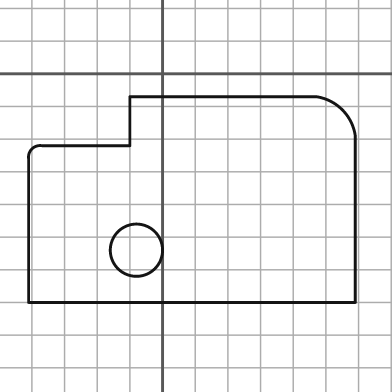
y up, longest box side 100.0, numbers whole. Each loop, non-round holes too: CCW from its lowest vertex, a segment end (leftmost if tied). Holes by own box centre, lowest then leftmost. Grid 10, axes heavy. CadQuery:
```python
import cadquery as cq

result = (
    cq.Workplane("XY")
    .moveTo(-41.0, -70.0)
    .lineTo(59.0, -70.0)
    .lineTo(59.0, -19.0)
    .threePointArc((55.0, -11.0), (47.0, -7.0))
    .lineTo(-10.0, -7.0)
    .lineTo(-10.0, -22.0)
    .lineTo(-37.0, -22.0)
    .threePointArc((-40.0, -23.0), (-41.0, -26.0))
    .close()
    .moveTo(-8.0, -54.0)
    .circle(8.0)
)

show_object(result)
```